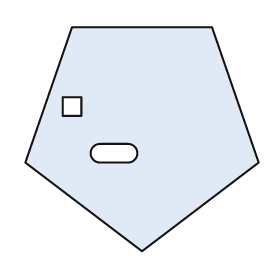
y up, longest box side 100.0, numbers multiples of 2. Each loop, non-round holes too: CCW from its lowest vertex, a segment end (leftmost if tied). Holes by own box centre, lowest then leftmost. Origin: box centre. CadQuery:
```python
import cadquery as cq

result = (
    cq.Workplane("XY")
    .moveTo(0.0, -48.0)
    .lineTo(50.0, -10.0)
    .lineTo(30.0, 48.0)
    .lineTo(-30.0, 48.0)
    .lineTo(-50.0, -10.0)
    .close()
    .moveTo(-18.0, -10.0)
    .lineTo(-6.0, -10.0)
    .threePointArc((-2.0, -6.0), (-6.0, -2.0))
    .lineTo(-18.0, -2.0)
    .threePointArc((-22.0, -6.0), (-18.0, -10.0))
    .close()
    .moveTo(-34.0, 10.0)
    .lineTo(-26.0, 10.0)
    .lineTo(-26.0, 18.0)
    .lineTo(-34.0, 18.0)
    .close()
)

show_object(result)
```